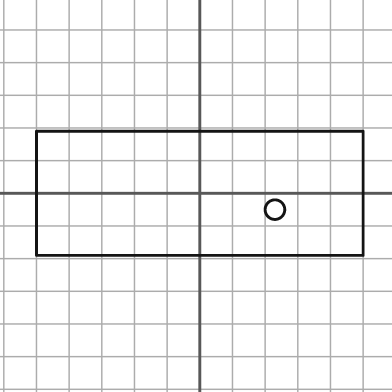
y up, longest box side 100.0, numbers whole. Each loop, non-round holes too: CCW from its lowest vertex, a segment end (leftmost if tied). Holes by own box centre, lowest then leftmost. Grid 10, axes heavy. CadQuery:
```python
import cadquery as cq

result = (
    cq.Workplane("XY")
    .moveTo(-50.0, -19.0)
    .lineTo(50.0, -19.0)
    .lineTo(50.0, 19.0)
    .lineTo(-50.0, 19.0)
    .close()
    .moveTo(23.0, -5.0)
    .circle(3.0)
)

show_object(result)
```